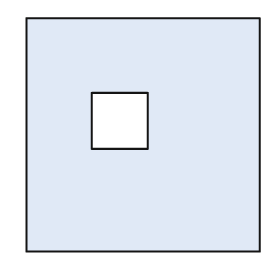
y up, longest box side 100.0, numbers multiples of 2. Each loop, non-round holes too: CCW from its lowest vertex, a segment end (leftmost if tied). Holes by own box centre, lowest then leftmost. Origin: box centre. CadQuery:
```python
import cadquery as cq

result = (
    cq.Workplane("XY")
    .moveTo(-50.0, -50.0)
    .lineTo(50.0, -50.0)
    .lineTo(50.0, 50.0)
    .lineTo(-50.0, 50.0)
    .close()
    .moveTo(-22.0, -6.0)
    .lineTo(2.0, -6.0)
    .lineTo(2.0, 18.0)
    .lineTo(-22.0, 18.0)
    .close()
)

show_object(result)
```